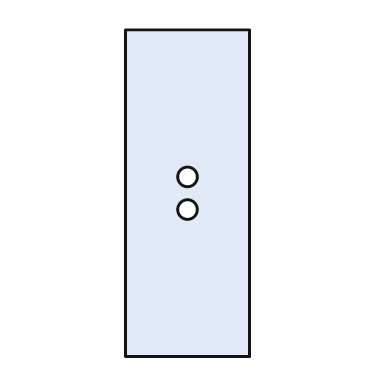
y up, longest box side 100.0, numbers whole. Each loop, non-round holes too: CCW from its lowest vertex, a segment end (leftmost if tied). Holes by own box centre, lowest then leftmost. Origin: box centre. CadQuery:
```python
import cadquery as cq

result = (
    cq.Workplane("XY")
    .moveTo(-19.0, -50.0)
    .lineTo(19.0, -50.0)
    .lineTo(19.0, 50.0)
    .lineTo(-19.0, 50.0)
    .close()
    .moveTo(0.0, -5.0)
    .circle(3.0)
    .moveTo(0.0, 5.0)
    .circle(3.0)
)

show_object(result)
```